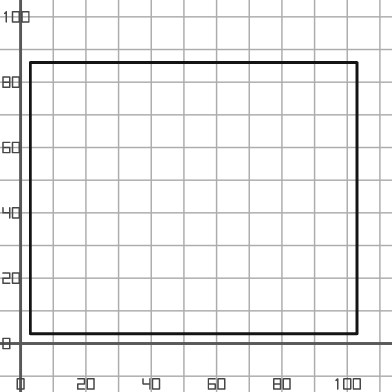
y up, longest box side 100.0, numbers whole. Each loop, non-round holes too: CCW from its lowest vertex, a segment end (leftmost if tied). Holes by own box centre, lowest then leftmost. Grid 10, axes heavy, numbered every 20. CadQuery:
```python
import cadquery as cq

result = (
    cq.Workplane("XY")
    .moveTo(3.0, 3.0)
    .lineTo(103.0, 3.0)
    .lineTo(103.0, 86.0)
    .lineTo(3.0, 86.0)
    .close()
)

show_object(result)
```